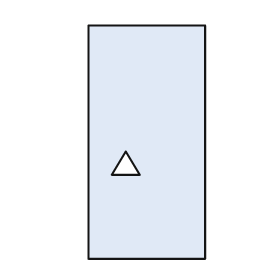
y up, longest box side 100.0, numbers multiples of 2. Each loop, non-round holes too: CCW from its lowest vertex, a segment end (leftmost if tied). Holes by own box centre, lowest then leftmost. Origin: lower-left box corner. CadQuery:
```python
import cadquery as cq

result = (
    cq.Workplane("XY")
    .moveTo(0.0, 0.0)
    .lineTo(50.0, 0.0)
    .lineTo(50.0, 100.0)
    .lineTo(0.0, 100.0)
    .close()
    .moveTo(10.0, 36.0)
    .lineTo(22.0, 36.0)
    .lineTo(16.0, 46.0)
    .close()
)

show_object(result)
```